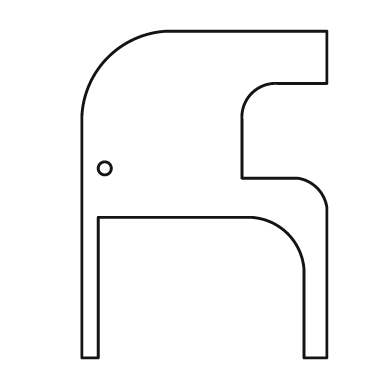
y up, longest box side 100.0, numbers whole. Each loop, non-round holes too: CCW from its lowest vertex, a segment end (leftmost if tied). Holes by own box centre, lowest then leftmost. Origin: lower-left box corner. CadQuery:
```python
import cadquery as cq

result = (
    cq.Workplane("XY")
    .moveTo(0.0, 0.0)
    .lineTo(5.0, 0.0)
    .lineTo(5.0, 43.0)
    .lineTo(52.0, 43.0)
    .threePointArc((63.0, 38.0), (68.0, 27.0))
    .lineTo(68.0, 0.0)
    .lineTo(75.0, 0.0)
    .lineTo(75.0, 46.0)
    .threePointArc((72.0, 52.0), (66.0, 55.0))
    .lineTo(49.0, 55.0)
    .lineTo(49.0, 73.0)
    .threePointArc((52.0, 81.0), (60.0, 84.0))
    .lineTo(75.0, 84.0)
    .lineTo(75.0, 100.0)
    .lineTo(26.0, 100.0)
    .threePointArc((8.0, 92.0), (0.0, 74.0))
    .close()
    .moveTo(7.0, 58.0)
    .circle(2.0)
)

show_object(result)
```